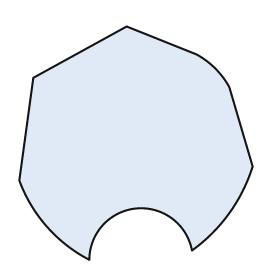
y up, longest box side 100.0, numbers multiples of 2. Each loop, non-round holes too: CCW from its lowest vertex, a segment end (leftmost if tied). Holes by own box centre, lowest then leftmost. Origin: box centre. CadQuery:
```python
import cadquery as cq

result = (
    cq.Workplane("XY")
    .moveTo(-20.0, -50.0)
    .threePointArc((0.0, -28.0), (24.0, -46.0))
    .threePointArc((40.0, -30.0), (50.0, -10.0))
    .lineTo(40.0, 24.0)
    .threePointArc((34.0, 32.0), (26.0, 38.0))
    .lineTo(-4.0, 50.0)
    .lineTo(-44.0, 28.0)
    .lineTo(-50.0, -16.0)
    .threePointArc((-38.0, -36.0), (-20.0, -50.0))
    .close()
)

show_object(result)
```